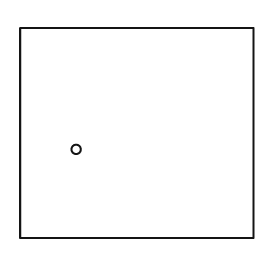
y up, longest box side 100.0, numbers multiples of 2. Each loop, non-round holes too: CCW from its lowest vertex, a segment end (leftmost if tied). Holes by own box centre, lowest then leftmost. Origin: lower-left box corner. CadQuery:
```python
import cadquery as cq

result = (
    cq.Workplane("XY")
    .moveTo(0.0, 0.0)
    .lineTo(100.0, 0.0)
    .lineTo(100.0, 90.0)
    .lineTo(0.0, 90.0)
    .close()
    .moveTo(24.0, 38.0)
    .circle(2.0)
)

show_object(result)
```